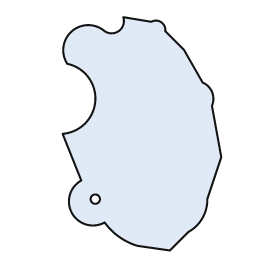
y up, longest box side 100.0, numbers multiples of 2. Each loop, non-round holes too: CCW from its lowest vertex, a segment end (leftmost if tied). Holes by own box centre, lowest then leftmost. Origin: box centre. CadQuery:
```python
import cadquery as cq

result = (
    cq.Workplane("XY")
    .moveTo(12.0, -50.0)
    .lineTo(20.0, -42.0)
    .threePointArc((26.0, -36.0), (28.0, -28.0))
    .lineTo(34.0, -10.0)
    .lineTo(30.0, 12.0)
    .threePointArc((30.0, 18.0), (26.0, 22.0))
    .lineTo(18.0, 36.0)
    .lineTo(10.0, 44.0)
    .threePointArc((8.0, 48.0), (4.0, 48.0))
    .lineTo(-8.0, 50.0)
    .threePointArc((-10.0, 44.0), (-16.0, 44.0))
    .threePointArc((-30.0, 44.0), (-32.0, 30.0))
    .threePointArc((-20.0, 14.0), (-34.0, 0.0))
    .lineTo(-26.0, -20.0)
    .threePointArc((-30.0, -34.0), (-16.0, -38.0))
    .threePointArc((-10.0, -44.0), (-2.0, -48.0))
    .close()
    .moveTo(-20.0, -28.0)
    .circle(2.0)
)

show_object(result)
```